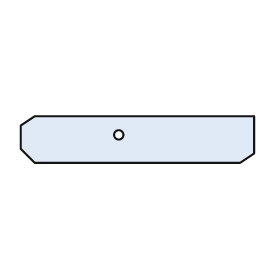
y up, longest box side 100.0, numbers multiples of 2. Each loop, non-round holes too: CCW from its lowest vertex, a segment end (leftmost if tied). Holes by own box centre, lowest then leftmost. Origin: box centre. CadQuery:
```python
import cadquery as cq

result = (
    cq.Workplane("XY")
    .moveTo(-44.0, -10.0)
    .lineTo(44.0, -10.0)
    .lineTo(50.0, -6.0)
    .lineTo(50.0, 10.0)
    .lineTo(-44.0, 10.0)
    .lineTo(-50.0, 6.0)
    .lineTo(-50.0, -4.0)
    .close()
    .moveTo(-8.0, 2.0)
    .circle(2.0)
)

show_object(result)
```